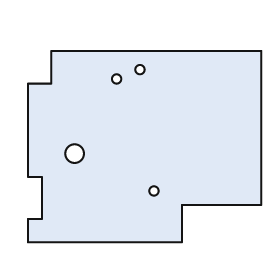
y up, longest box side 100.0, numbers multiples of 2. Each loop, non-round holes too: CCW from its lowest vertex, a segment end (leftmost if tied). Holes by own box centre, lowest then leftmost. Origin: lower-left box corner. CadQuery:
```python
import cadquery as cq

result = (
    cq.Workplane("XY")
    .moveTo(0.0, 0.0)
    .lineTo(66.0, 0.0)
    .lineTo(66.0, 16.0)
    .lineTo(100.0, 16.0)
    .lineTo(100.0, 82.0)
    .lineTo(10.0, 82.0)
    .lineTo(10.0, 68.0)
    .lineTo(0.0, 68.0)
    .lineTo(0.0, 28.0)
    .lineTo(6.0, 28.0)
    .lineTo(6.0, 10.0)
    .lineTo(0.0, 10.0)
    .close()
    .moveTo(54.0, 22.0)
    .circle(2.0)
    .moveTo(20.0, 38.0)
    .circle(4.0)
    .moveTo(38.0, 70.0)
    .circle(2.0)
    .moveTo(48.0, 74.0)
    .circle(2.0)
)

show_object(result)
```